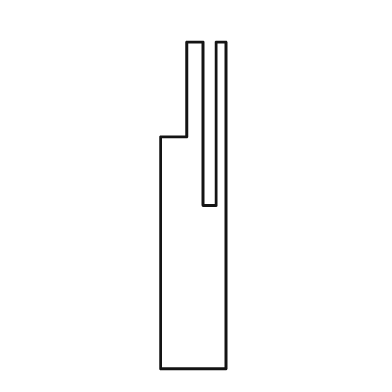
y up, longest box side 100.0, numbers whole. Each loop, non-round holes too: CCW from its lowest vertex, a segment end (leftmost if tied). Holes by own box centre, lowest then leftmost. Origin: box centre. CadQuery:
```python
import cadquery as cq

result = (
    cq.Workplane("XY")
    .moveTo(-10.0, -50.0)
    .lineTo(10.0, -50.0)
    .lineTo(10.0, 50.0)
    .lineTo(7.0, 50.0)
    .lineTo(7.0, 0.0)
    .lineTo(3.0, 0.0)
    .lineTo(3.0, 50.0)
    .lineTo(-2.0, 50.0)
    .lineTo(-2.0, 21.0)
    .lineTo(-10.0, 21.0)
    .close()
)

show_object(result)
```